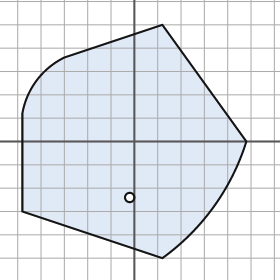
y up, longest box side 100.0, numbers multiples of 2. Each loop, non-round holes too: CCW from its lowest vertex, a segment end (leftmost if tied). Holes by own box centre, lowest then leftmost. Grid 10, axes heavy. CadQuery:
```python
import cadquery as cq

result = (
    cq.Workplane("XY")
    .moveTo(12.0, -50.0)
    .threePointArc((34.0, -28.0), (48.0, 0.0))
    .lineTo(12.0, 50.0)
    .lineTo(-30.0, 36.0)
    .threePointArc((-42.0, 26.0), (-48.0, 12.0))
    .lineTo(-48.0, -30.0)
    .close()
    .moveTo(-2.0, -24.0)
    .circle(2.0)
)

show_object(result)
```